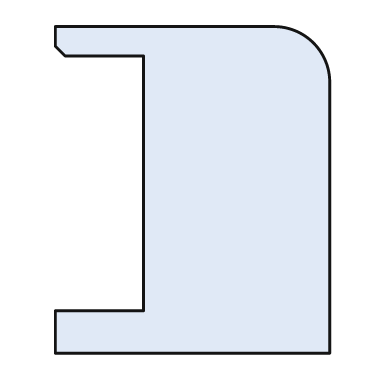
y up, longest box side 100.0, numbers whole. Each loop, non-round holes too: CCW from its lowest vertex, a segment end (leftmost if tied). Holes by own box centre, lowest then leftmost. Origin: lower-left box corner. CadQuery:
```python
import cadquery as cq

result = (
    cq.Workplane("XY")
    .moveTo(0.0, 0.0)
    .lineTo(84.0, 0.0)
    .lineTo(84.0, 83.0)
    .threePointArc((79.0, 95.0), (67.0, 100.0))
    .lineTo(0.0, 100.0)
    .lineTo(0.0, 94.0)
    .lineTo(3.0, 91.0)
    .lineTo(27.0, 91.0)
    .lineTo(27.0, 13.0)
    .lineTo(0.0, 13.0)
    .close()
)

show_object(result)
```